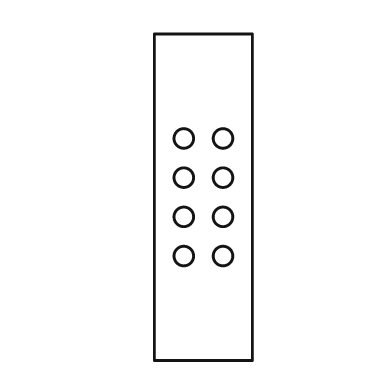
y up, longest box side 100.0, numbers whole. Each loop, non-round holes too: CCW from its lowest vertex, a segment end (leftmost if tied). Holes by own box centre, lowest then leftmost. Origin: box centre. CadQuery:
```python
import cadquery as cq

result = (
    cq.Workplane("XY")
    .moveTo(-15.0, -50.0)
    .lineTo(15.0, -50.0)
    .lineTo(15.0, 50.0)
    .lineTo(-15.0, 50.0)
    .close()
    .moveTo(-6.0, -18.0)
    .circle(3.0)
    .moveTo(6.0, -18.0)
    .circle(3.0)
    .moveTo(-6.0, -6.0)
    .circle(3.0)
    .moveTo(6.0, -6.0)
    .circle(3.0)
    .moveTo(-6.0, 6.0)
    .circle(3.0)
    .moveTo(6.0, 6.0)
    .circle(3.0)
    .moveTo(-6.0, 18.0)
    .circle(3.0)
    .moveTo(6.0, 18.0)
    .circle(3.0)
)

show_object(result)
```